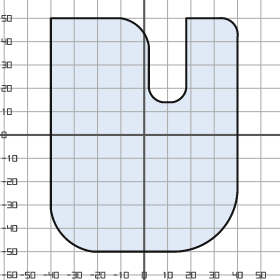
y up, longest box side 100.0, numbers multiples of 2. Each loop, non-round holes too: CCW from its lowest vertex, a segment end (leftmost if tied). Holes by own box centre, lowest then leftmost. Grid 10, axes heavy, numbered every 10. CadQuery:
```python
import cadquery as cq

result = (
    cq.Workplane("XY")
    .moveTo(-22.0, -50.0)
    .lineTo(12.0, -50.0)
    .threePointArc((32.0, -42.0), (40.0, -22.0))
    .lineTo(40.0, 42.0)
    .threePointArc((38.0, 48.0), (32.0, 50.0))
    .lineTo(18.0, 50.0)
    .lineTo(18.0, 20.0)
    .threePointArc((16.0, 16.0), (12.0, 14.0))
    .lineTo(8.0, 14.0)
    .threePointArc((4.0, 16.0), (2.0, 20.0))
    .lineTo(2.0, 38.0)
    .threePointArc((-2.0, 46.0), (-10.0, 50.0))
    .lineTo(-40.0, 50.0)
    .lineTo(-40.0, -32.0)
    .threePointArc((-34.0, -44.0), (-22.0, -50.0))
    .close()
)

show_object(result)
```